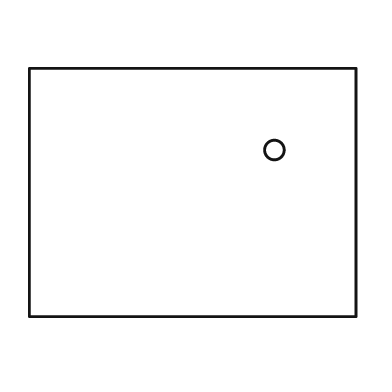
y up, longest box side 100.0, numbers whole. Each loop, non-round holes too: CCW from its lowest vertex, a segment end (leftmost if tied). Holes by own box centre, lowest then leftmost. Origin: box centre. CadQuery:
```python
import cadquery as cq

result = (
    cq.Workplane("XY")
    .moveTo(-50.0, -38.0)
    .lineTo(50.0, -38.0)
    .lineTo(50.0, 38.0)
    .lineTo(-50.0, 38.0)
    .close()
    .moveTo(25.0, 13.0)
    .circle(3.0)
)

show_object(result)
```